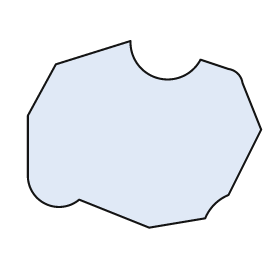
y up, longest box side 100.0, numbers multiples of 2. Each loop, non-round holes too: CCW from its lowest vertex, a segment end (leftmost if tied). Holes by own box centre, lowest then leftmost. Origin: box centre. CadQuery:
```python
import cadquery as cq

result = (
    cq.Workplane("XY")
    .moveTo(2.0, -40.0)
    .lineTo(26.0, -36.0)
    .threePointArc((30.0, -30.0), (36.0, -26.0))
    .lineTo(50.0, 2.0)
    .lineTo(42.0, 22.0)
    .threePointArc((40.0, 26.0), (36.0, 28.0))
    .lineTo(24.0, 32.0)
    .threePointArc((6.0, 24.0), (-6.0, 40.0))
    .lineTo(-38.0, 30.0)
    .lineTo(-50.0, 8.0)
    .lineTo(-50.0, -18.0)
    .threePointArc((-42.0, -30.0), (-28.0, -28.0))
    .close()
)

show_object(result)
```